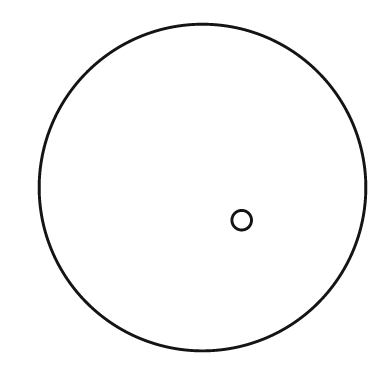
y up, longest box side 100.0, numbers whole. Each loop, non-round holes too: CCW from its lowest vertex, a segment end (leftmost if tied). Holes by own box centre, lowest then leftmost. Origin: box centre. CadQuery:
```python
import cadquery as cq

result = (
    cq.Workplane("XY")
    .moveTo(0.0, 0.0)
    .circle(50.0)
    .moveTo(12.0, -10.0)
    .circle(3.0)
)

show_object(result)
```